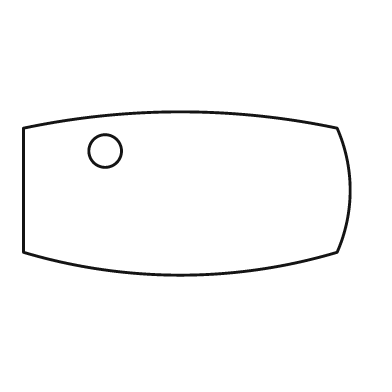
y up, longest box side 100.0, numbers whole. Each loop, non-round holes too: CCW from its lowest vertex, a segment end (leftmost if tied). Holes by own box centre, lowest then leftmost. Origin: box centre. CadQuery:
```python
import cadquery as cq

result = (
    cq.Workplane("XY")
    .moveTo(-50.0, -18.0)
    .threePointArc((-2.0, -25.0), (46.0, -18.0))
    .threePointArc((50.0, 1.0), (46.0, 20.0))
    .threePointArc((-2.0, 25.0), (-50.0, 20.0))
    .close()
    .moveTo(-25.0, 13.0)
    .circle(5.0)
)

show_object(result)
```